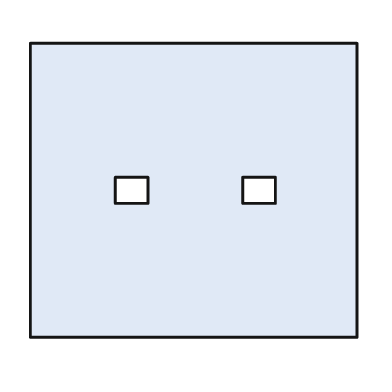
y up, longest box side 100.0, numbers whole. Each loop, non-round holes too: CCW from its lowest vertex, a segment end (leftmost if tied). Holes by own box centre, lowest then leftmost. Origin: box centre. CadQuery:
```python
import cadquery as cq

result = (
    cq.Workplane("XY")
    .moveTo(-50.0, -45.0)
    .lineTo(50.0, -45.0)
    .lineTo(50.0, 45.0)
    .lineTo(-50.0, 45.0)
    .close()
    .moveTo(-24.0, -4.0)
    .lineTo(-14.0, -4.0)
    .lineTo(-14.0, 4.0)
    .lineTo(-24.0, 4.0)
    .close()
    .moveTo(15.0, -4.0)
    .lineTo(25.0, -4.0)
    .lineTo(25.0, 4.0)
    .lineTo(15.0, 4.0)
    .close()
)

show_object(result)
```